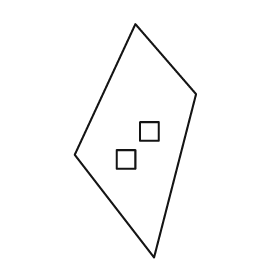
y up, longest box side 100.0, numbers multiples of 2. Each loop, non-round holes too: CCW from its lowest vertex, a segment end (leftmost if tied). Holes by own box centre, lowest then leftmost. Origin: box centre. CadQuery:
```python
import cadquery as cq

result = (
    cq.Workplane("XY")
    .moveTo(8.0, -50.0)
    .lineTo(26.0, 20.0)
    .lineTo(0.0, 50.0)
    .lineTo(-26.0, -6.0)
    .close()
    .moveTo(-8.0, -12.0)
    .lineTo(0.0, -12.0)
    .lineTo(0.0, -4.0)
    .lineTo(-8.0, -4.0)
    .close()
    .moveTo(2.0, 0.0)
    .lineTo(10.0, 0.0)
    .lineTo(10.0, 8.0)
    .lineTo(2.0, 8.0)
    .close()
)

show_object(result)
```